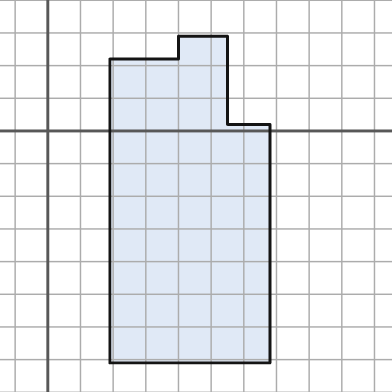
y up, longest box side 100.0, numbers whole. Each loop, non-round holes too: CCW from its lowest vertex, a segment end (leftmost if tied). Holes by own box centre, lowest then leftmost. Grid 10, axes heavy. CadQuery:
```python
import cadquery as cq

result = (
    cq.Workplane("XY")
    .moveTo(19.0, -71.0)
    .lineTo(68.0, -71.0)
    .lineTo(68.0, 2.0)
    .lineTo(55.0, 2.0)
    .lineTo(55.0, 29.0)
    .lineTo(40.0, 29.0)
    .lineTo(40.0, 22.0)
    .lineTo(19.0, 22.0)
    .close()
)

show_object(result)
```